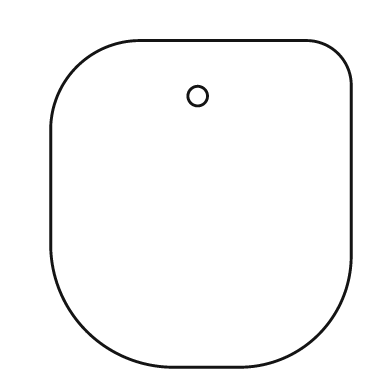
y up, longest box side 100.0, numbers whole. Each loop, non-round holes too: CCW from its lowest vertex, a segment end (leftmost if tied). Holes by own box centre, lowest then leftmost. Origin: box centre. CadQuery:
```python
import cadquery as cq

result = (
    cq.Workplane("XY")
    .moveTo(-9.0, -50.0)
    .lineTo(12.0, -50.0)
    .threePointArc((36.0, -40.0), (46.0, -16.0))
    .lineTo(46.0, 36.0)
    .threePointArc((42.0, 46.0), (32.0, 50.0))
    .lineTo(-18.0, 50.0)
    .threePointArc((-38.0, 42.0), (-46.0, 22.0))
    .lineTo(-46.0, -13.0)
    .threePointArc((-35.0, -39.0), (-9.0, -50.0))
    .close()
    .moveTo(-1.0, 33.0)
    .circle(3.0)
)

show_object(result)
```